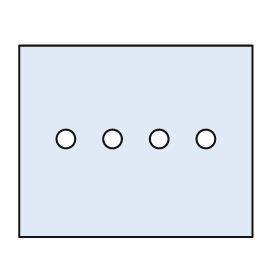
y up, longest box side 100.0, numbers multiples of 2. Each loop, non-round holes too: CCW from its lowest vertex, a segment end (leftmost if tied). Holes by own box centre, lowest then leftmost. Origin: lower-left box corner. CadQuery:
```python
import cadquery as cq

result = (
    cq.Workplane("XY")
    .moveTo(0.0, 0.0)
    .lineTo(100.0, 0.0)
    .lineTo(100.0, 82.0)
    .lineTo(0.0, 82.0)
    .close()
    .moveTo(20.0, 42.0)
    .circle(4.0)
    .moveTo(40.0, 42.0)
    .circle(4.0)
    .moveTo(60.0, 42.0)
    .circle(4.0)
    .moveTo(80.0, 42.0)
    .circle(4.0)
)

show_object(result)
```